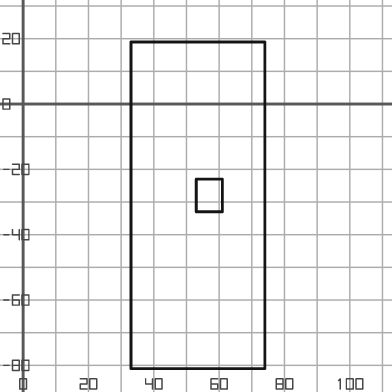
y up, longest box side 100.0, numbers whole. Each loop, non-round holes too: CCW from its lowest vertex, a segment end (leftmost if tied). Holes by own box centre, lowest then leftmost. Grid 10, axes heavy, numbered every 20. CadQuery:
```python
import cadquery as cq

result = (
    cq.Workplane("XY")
    .moveTo(33.0, -81.0)
    .lineTo(74.0, -81.0)
    .lineTo(74.0, 19.0)
    .lineTo(33.0, 19.0)
    .close()
    .moveTo(53.0, -33.0)
    .lineTo(61.0, -33.0)
    .lineTo(61.0, -23.0)
    .lineTo(53.0, -23.0)
    .close()
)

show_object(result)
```